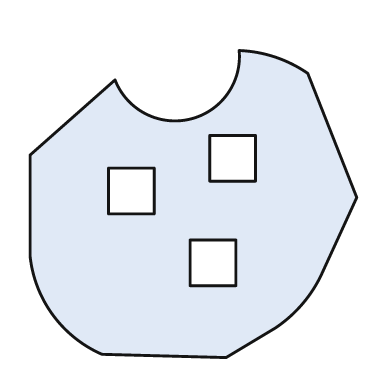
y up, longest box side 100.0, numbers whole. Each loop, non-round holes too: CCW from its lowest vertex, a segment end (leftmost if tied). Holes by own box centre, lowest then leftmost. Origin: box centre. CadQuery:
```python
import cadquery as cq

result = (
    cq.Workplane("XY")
    .moveTo(10.0, -47.0)
    .lineTo(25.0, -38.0)
    .threePointArc((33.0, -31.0), (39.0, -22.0))
    .lineTo(50.0, 2.0)
    .lineTo(35.0, 40.0)
    .threePointArc((25.0, 45.0), (14.0, 47.0))
    .threePointArc((-1.0, 26.0), (-24.0, 38.0))
    .lineTo(-50.0, 15.0)
    .lineTo(-50.0, -16.0)
    .threePointArc((-43.0, -34.0), (-28.0, -46.0))
    .close()
    .moveTo(-1.0, -25.0)
    .lineTo(13.0, -25.0)
    .lineTo(13.0, -11.0)
    .lineTo(-1.0, -11.0)
    .close()
    .moveTo(-26.0, -3.0)
    .lineTo(-12.0, -3.0)
    .lineTo(-12.0, 11.0)
    .lineTo(-26.0, 11.0)
    .close()
    .moveTo(5.0, 7.0)
    .lineTo(19.0, 7.0)
    .lineTo(19.0, 21.0)
    .lineTo(5.0, 21.0)
    .close()
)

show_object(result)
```